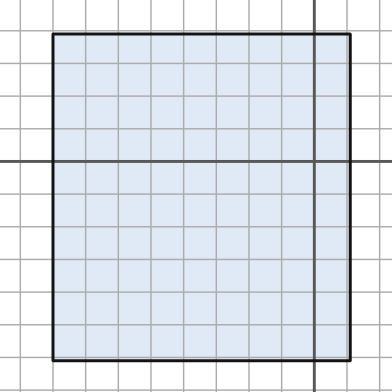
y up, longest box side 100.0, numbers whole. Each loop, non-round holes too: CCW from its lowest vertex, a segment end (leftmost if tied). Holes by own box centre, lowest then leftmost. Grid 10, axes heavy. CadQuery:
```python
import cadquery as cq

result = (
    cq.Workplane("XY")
    .moveTo(-80.0, -61.0)
    .lineTo(11.0, -61.0)
    .lineTo(11.0, 39.0)
    .lineTo(-80.0, 39.0)
    .close()
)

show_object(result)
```